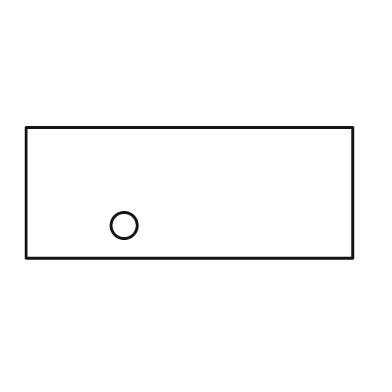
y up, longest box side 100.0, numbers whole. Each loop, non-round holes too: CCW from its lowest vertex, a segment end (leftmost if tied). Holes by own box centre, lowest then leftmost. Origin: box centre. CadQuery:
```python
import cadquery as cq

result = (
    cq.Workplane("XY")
    .moveTo(-50.0, -20.0)
    .lineTo(50.0, -20.0)
    .lineTo(50.0, 20.0)
    .lineTo(-50.0, 20.0)
    .close()
    .moveTo(-20.0, -10.0)
    .circle(4.0)
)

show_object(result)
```